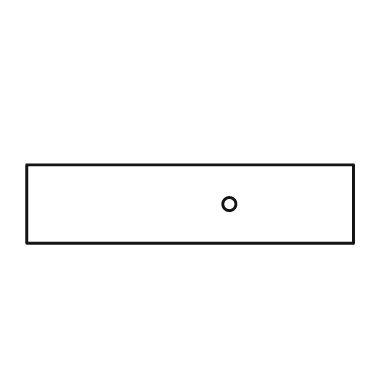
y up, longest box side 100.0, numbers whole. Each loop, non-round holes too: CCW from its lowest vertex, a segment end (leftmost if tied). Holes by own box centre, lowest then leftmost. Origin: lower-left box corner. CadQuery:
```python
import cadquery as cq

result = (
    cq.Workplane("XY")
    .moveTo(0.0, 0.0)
    .lineTo(100.0, 0.0)
    .lineTo(100.0, 24.0)
    .lineTo(0.0, 24.0)
    .close()
    .moveTo(62.0, 12.0)
    .circle(2.0)
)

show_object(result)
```